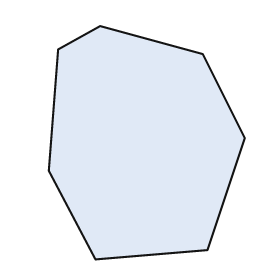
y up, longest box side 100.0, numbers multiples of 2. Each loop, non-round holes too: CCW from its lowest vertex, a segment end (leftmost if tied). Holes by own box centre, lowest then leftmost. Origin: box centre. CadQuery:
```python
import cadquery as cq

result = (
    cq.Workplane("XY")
    .moveTo(-22.0, -50.0)
    .lineTo(26.0, -46.0)
    .lineTo(42.0, 2.0)
    .lineTo(24.0, 38.0)
    .lineTo(-20.0, 50.0)
    .lineTo(-38.0, 40.0)
    .lineTo(-42.0, -12.0)
    .close()
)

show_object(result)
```